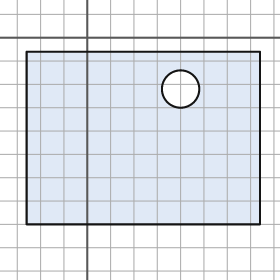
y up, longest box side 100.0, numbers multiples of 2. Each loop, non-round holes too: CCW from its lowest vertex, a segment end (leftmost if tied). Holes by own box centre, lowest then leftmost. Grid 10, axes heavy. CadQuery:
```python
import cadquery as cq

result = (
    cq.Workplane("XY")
    .moveTo(-26.0, -80.0)
    .lineTo(74.0, -80.0)
    .lineTo(74.0, -6.0)
    .lineTo(-26.0, -6.0)
    .close()
    .moveTo(40.0, -22.0)
    .circle(8.0)
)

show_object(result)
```